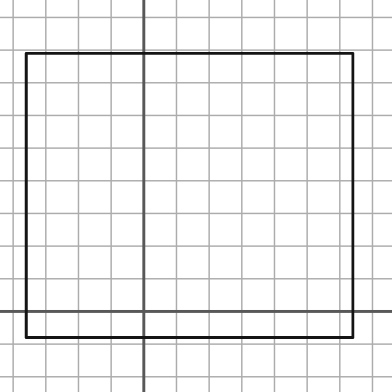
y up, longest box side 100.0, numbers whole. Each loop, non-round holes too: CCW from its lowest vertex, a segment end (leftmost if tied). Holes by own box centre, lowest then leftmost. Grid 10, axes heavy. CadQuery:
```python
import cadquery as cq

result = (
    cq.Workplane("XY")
    .moveTo(-36.0, -8.0)
    .lineTo(64.0, -8.0)
    .lineTo(64.0, 79.0)
    .lineTo(-36.0, 79.0)
    .close()
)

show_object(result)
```